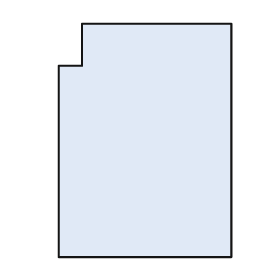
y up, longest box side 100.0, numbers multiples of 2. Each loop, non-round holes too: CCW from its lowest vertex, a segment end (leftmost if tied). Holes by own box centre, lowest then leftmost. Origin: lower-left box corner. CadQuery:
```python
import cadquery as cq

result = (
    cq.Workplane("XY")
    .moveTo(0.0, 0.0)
    .lineTo(74.0, 0.0)
    .lineTo(74.0, 100.0)
    .lineTo(10.0, 100.0)
    .lineTo(10.0, 82.0)
    .lineTo(0.0, 82.0)
    .close()
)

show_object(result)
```